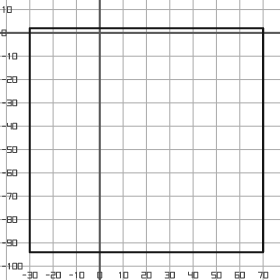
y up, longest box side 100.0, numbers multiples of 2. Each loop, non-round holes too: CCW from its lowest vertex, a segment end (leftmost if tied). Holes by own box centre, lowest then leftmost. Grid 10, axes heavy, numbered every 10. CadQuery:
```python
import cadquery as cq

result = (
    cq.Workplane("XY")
    .moveTo(-30.0, -94.0)
    .lineTo(70.0, -94.0)
    .lineTo(70.0, 2.0)
    .lineTo(-30.0, 2.0)
    .close()
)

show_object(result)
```